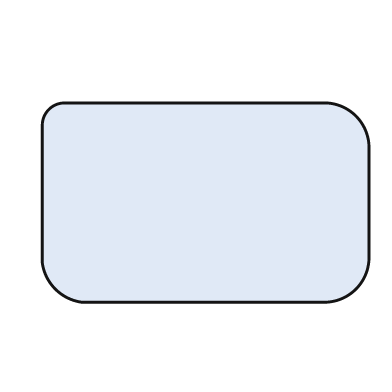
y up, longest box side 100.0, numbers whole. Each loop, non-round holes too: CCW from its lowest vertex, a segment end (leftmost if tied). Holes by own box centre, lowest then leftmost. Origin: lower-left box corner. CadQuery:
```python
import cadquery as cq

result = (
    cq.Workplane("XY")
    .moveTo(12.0, 0.0)
    .lineTo(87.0, 0.0)
    .threePointArc((96.0, 4.0), (100.0, 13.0))
    .lineTo(100.0, 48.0)
    .threePointArc((96.0, 57.0), (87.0, 61.0))
    .lineTo(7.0, 61.0)
    .threePointArc((2.0, 59.0), (0.0, 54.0))
    .lineTo(0.0, 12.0)
    .threePointArc((4.0, 4.0), (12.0, 0.0))
    .close()
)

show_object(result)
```